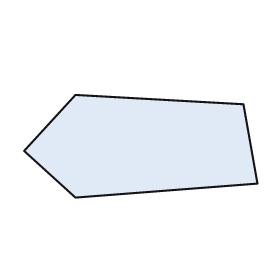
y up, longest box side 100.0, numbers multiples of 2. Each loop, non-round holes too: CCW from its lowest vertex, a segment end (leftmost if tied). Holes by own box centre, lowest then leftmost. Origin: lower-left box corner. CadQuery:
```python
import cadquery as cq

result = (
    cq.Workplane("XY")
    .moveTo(22.0, 0.0)
    .lineTo(100.0, 6.0)
    .lineTo(94.0, 40.0)
    .lineTo(22.0, 44.0)
    .lineTo(0.0, 20.0)
    .close()
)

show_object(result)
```